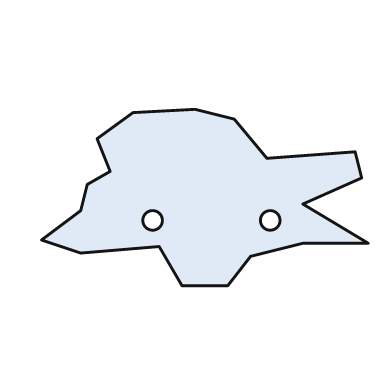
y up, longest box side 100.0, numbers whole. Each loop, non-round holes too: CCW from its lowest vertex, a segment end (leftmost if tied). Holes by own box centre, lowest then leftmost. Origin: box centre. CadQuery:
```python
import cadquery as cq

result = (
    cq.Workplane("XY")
    .moveTo(-7.0, -27.0)
    .lineTo(7.0, -27.0)
    .lineTo(14.0, -18.0)
    .lineTo(30.0, -14.0)
    .lineTo(50.0, -14.0)
    .lineTo(30.0, -2.0)
    .lineTo(48.0, 6.0)
    .lineTo(46.0, 14.0)
    .lineTo(19.0, 12.0)
    .lineTo(9.0, 24.0)
    .lineTo(-3.0, 27.0)
    .lineTo(-22.0, 26.0)
    .lineTo(-33.0, 18.0)
    .lineTo(-29.0, 8.0)
    .lineTo(-36.0, 4.0)
    .lineTo(-38.0, -4.0)
    .lineTo(-50.0, -13.0)
    .lineTo(-38.0, -17.0)
    .lineTo(-14.0, -15.0)
    .close()
    .moveTo(-16.0, -7.0)
    .circle(3.0)
    .moveTo(20.0, -7.0)
    .circle(3.0)
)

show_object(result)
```